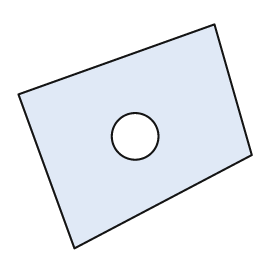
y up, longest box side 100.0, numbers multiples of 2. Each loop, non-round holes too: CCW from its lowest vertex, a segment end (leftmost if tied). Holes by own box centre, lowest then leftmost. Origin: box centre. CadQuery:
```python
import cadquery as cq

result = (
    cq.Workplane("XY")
    .moveTo(-26.0, -48.0)
    .lineTo(50.0, -8.0)
    .lineTo(34.0, 48.0)
    .lineTo(-50.0, 18.0)
    .close()
    .moveTo(0.0, 0.0)
    .circle(10.0)
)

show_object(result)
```